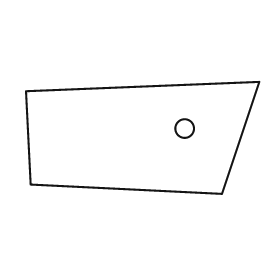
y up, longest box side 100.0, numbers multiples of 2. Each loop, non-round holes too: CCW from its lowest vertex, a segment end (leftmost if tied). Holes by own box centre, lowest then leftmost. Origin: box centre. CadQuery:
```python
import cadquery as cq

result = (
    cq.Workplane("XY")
    .moveTo(34.0, -24.0)
    .lineTo(50.0, 24.0)
    .lineTo(-50.0, 20.0)
    .lineTo(-48.0, -20.0)
    .close()
    .moveTo(18.0, 4.0)
    .circle(4.0)
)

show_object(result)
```